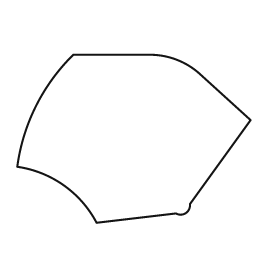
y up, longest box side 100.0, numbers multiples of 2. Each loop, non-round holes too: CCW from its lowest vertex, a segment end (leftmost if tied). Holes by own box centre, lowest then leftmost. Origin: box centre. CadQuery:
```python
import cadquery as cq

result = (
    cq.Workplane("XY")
    .moveTo(-16.0, -36.0)
    .lineTo(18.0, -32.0)
    .threePointArc((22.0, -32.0), (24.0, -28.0))
    .lineTo(50.0, 8.0)
    .lineTo(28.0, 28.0)
    .threePointArc((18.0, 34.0), (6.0, 36.0))
    .lineTo(-26.0, 36.0)
    .threePointArc((-42.0, 14.0), (-50.0, -12.0))
    .threePointArc((-30.0, -20.0), (-16.0, -36.0))
    .close()
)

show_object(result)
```